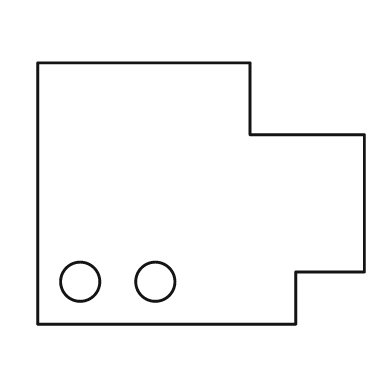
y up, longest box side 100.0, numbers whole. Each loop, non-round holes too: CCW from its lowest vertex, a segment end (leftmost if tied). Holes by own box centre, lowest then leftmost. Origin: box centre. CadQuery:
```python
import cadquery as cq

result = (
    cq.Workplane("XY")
    .moveTo(-50.0, -40.0)
    .lineTo(29.0, -40.0)
    .lineTo(29.0, -24.0)
    .lineTo(50.0, -24.0)
    .lineTo(50.0, 18.0)
    .lineTo(15.0, 18.0)
    .lineTo(15.0, 40.0)
    .lineTo(-50.0, 40.0)
    .close()
    .moveTo(-37.0, -27.0)
    .circle(6.0)
    .moveTo(-14.0, -27.0)
    .circle(6.0)
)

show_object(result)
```